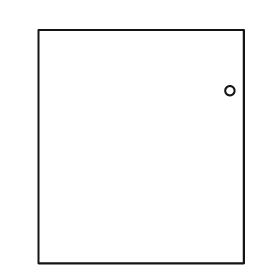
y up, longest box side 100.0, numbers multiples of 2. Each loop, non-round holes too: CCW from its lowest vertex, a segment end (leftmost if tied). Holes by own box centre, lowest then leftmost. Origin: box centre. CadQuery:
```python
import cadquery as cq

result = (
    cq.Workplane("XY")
    .moveTo(-44.0, -50.0)
    .lineTo(44.0, -50.0)
    .lineTo(44.0, 50.0)
    .lineTo(-44.0, 50.0)
    .close()
    .moveTo(38.0, 24.0)
    .circle(2.0)
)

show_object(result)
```